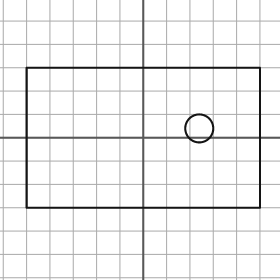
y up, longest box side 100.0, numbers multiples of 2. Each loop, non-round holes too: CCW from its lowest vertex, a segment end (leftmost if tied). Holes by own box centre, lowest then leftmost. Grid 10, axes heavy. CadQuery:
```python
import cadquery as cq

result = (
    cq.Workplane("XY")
    .moveTo(-50.0, -30.0)
    .lineTo(50.0, -30.0)
    .lineTo(50.0, 30.0)
    .lineTo(-50.0, 30.0)
    .close()
    .moveTo(24.0, 4.0)
    .circle(6.0)
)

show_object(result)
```